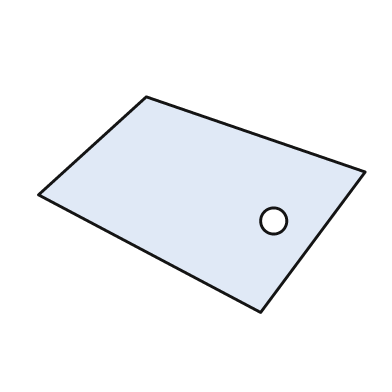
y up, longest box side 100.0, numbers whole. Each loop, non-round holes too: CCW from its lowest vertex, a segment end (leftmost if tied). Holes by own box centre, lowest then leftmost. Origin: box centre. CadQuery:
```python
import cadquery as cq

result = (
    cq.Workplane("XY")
    .moveTo(18.0, -33.0)
    .lineTo(50.0, 10.0)
    .lineTo(-17.0, 33.0)
    .lineTo(-50.0, 3.0)
    .close()
    .moveTo(22.0, -5.0)
    .circle(4.0)
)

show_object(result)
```